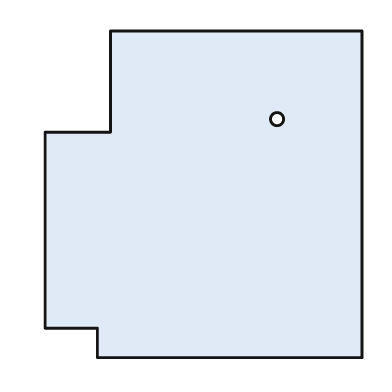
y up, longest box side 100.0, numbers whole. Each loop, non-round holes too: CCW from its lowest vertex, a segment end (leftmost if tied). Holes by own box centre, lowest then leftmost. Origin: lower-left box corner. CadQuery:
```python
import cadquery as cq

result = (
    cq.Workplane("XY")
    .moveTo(16.0, 0.0)
    .lineTo(97.0, 0.0)
    .lineTo(97.0, 100.0)
    .lineTo(20.0, 100.0)
    .lineTo(20.0, 69.0)
    .lineTo(0.0, 69.0)
    .lineTo(0.0, 9.0)
    .lineTo(16.0, 9.0)
    .close()
    .moveTo(71.0, 73.0)
    .circle(2.0)
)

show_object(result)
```